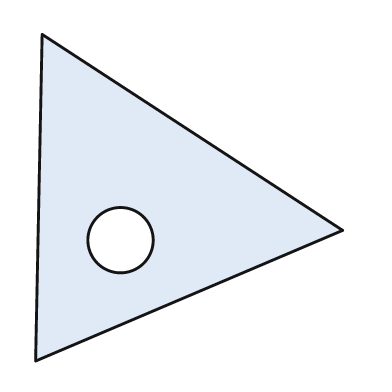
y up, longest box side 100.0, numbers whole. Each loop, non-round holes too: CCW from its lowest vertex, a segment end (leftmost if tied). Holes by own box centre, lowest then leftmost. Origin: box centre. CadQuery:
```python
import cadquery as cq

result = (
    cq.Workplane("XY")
    .moveTo(-47.0, -50.0)
    .lineTo(47.0, -10.0)
    .lineTo(-45.0, 50.0)
    .close()
    .moveTo(-21.0, -13.0)
    .circle(10.0)
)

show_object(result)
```